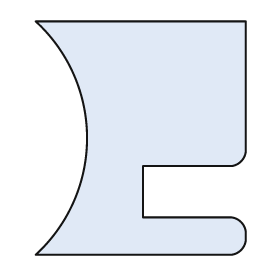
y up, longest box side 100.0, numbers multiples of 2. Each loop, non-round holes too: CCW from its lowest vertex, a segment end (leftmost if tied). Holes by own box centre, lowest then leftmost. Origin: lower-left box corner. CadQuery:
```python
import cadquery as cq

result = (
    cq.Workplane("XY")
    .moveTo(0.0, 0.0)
    .lineTo(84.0, 0.0)
    .threePointArc((88.0, 2.0), (90.0, 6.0))
    .lineTo(90.0, 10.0)
    .threePointArc((88.0, 14.0), (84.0, 16.0))
    .lineTo(46.0, 16.0)
    .lineTo(46.0, 38.0)
    .lineTo(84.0, 38.0)
    .threePointArc((88.0, 40.0), (90.0, 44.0))
    .lineTo(90.0, 100.0)
    .lineTo(0.0, 100.0)
    .threePointArc((22.0, 50.0), (0.0, 0.0))
    .close()
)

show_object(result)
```